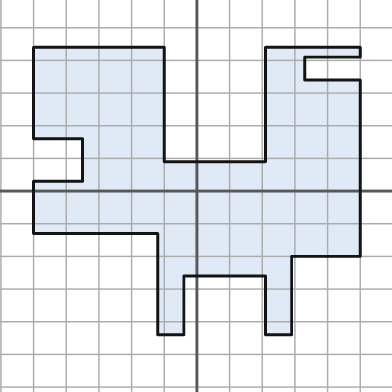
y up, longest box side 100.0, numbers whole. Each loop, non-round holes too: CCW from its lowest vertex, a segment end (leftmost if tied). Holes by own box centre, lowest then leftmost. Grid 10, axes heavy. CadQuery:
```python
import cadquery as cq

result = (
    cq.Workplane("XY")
    .moveTo(-12.0, -44.0)
    .lineTo(-4.0, -44.0)
    .lineTo(-4.0, -26.0)
    .lineTo(21.0, -26.0)
    .lineTo(21.0, -44.0)
    .lineTo(29.0, -44.0)
    .lineTo(29.0, -20.0)
    .lineTo(50.0, -20.0)
    .lineTo(50.0, 34.0)
    .lineTo(33.0, 34.0)
    .lineTo(33.0, 41.0)
    .lineTo(50.0, 41.0)
    .lineTo(50.0, 44.0)
    .lineTo(21.0, 44.0)
    .lineTo(21.0, 9.0)
    .lineTo(-10.0, 9.0)
    .lineTo(-10.0, 44.0)
    .lineTo(-50.0, 44.0)
    .lineTo(-50.0, 16.0)
    .lineTo(-35.0, 16.0)
    .lineTo(-35.0, 3.0)
    .lineTo(-50.0, 3.0)
    .lineTo(-50.0, -13.0)
    .lineTo(-12.0, -13.0)
    .close()
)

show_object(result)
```